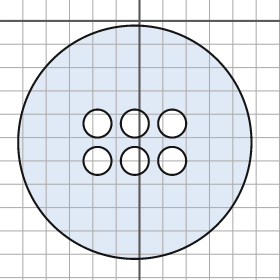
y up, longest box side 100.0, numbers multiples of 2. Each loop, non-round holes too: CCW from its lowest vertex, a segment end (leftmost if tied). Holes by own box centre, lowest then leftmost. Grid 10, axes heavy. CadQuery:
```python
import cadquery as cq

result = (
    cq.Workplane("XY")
    .moveTo(-2.0, -52.0)
    .circle(50.0)
    .moveTo(-18.0, -60.0)
    .circle(6.0)
    .moveTo(-2.0, -60.0)
    .circle(6.0)
    .moveTo(14.0, -60.0)
    .circle(6.0)
    .moveTo(-18.0, -44.0)
    .circle(6.0)
    .moveTo(-2.0, -44.0)
    .circle(6.0)
    .moveTo(14.0, -44.0)
    .circle(6.0)
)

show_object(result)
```